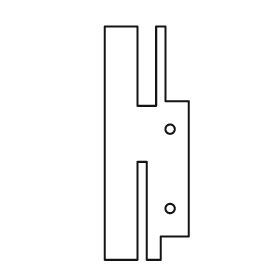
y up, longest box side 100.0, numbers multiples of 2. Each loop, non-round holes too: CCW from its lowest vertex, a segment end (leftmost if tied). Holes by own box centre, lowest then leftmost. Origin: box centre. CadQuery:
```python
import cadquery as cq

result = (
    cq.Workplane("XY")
    .moveTo(-18.0, -50.0)
    .lineTo(-4.0, -50.0)
    .lineTo(-4.0, -8.0)
    .lineTo(0.0, -8.0)
    .lineTo(0.0, -50.0)
    .lineTo(6.0, -50.0)
    .lineTo(6.0, -40.0)
    .lineTo(18.0, -40.0)
    .lineTo(18.0, 18.0)
    .lineTo(8.0, 18.0)
    .lineTo(8.0, 50.0)
    .lineTo(4.0, 50.0)
    .lineTo(4.0, 16.0)
    .lineTo(-4.0, 16.0)
    .lineTo(-4.0, 50.0)
    .lineTo(-18.0, 50.0)
    .close()
    .moveTo(10.0, -28.0)
    .circle(2.0)
    .moveTo(10.0, 6.0)
    .circle(2.0)
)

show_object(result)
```